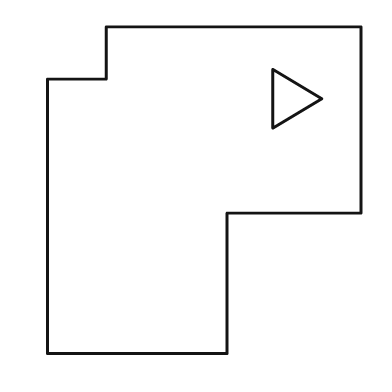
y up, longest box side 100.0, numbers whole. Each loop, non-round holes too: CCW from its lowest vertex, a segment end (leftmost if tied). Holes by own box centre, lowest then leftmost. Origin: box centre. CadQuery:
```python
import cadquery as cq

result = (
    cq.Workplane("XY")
    .moveTo(-48.0, -50.0)
    .lineTo(7.0, -50.0)
    .lineTo(7.0, -7.0)
    .lineTo(48.0, -7.0)
    .lineTo(48.0, 50.0)
    .lineTo(-30.0, 50.0)
    .lineTo(-30.0, 34.0)
    .lineTo(-48.0, 34.0)
    .close()
    .moveTo(21.0, 19.0)
    .lineTo(36.0, 28.0)
    .lineTo(21.0, 37.0)
    .close()
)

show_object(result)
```